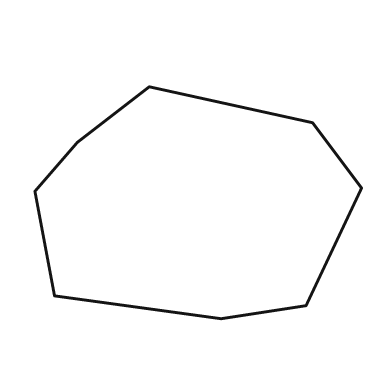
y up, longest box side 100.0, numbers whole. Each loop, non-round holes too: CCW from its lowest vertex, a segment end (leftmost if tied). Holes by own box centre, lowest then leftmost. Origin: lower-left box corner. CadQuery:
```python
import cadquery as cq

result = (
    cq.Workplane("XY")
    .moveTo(57.0, 0.0)
    .lineTo(83.0, 4.0)
    .lineTo(100.0, 40.0)
    .lineTo(85.0, 60.0)
    .lineTo(35.0, 71.0)
    .lineTo(13.0, 54.0)
    .lineTo(0.0, 39.0)
    .lineTo(6.0, 7.0)
    .close()
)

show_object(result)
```